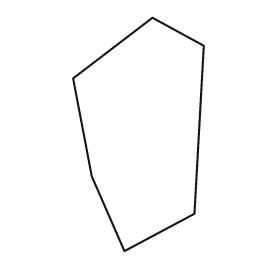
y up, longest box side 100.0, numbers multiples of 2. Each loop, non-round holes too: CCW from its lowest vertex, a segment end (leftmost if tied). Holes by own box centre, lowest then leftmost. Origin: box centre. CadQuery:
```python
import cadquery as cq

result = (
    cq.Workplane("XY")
    .moveTo(-6.0, -50.0)
    .lineTo(24.0, -34.0)
    .lineTo(28.0, 38.0)
    .lineTo(6.0, 50.0)
    .lineTo(-28.0, 24.0)
    .lineTo(-20.0, -18.0)
    .close()
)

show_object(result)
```